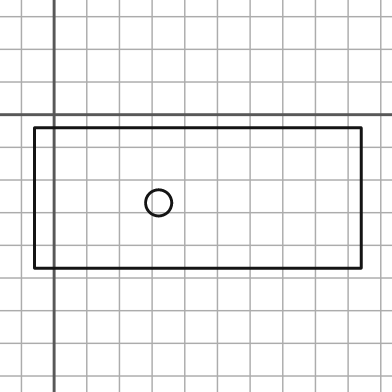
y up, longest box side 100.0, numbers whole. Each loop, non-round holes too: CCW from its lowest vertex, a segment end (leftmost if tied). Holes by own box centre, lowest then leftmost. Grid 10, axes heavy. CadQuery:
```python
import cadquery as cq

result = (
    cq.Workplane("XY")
    .moveTo(-6.0, -47.0)
    .lineTo(94.0, -47.0)
    .lineTo(94.0, -4.0)
    .lineTo(-6.0, -4.0)
    .close()
    .moveTo(32.0, -27.0)
    .circle(4.0)
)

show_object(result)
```